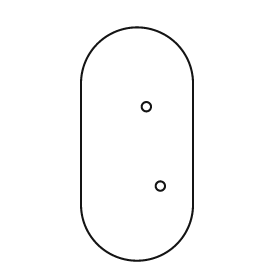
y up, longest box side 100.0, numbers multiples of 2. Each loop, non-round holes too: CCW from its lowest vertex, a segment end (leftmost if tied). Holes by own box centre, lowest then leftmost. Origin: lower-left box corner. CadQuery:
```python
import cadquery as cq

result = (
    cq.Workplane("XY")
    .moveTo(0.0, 24.0)
    .threePointArc((24.0, 0.0), (48.0, 24.0))
    .lineTo(48.0, 76.0)
    .threePointArc((24.0, 100.0), (0.0, 76.0))
    .close()
    .moveTo(34.0, 32.0)
    .circle(2.0)
    .moveTo(28.0, 66.0)
    .circle(2.0)
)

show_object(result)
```